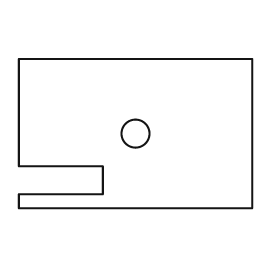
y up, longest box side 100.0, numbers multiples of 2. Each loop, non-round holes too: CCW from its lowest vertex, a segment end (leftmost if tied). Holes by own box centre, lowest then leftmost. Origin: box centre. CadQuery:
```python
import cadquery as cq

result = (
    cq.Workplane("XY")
    .moveTo(-50.0, -32.0)
    .lineTo(50.0, -32.0)
    .lineTo(50.0, 32.0)
    .lineTo(-50.0, 32.0)
    .lineTo(-50.0, -14.0)
    .lineTo(-14.0, -14.0)
    .lineTo(-14.0, -26.0)
    .lineTo(-50.0, -26.0)
    .close()
    .moveTo(0.0, 0.0)
    .circle(6.0)
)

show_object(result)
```